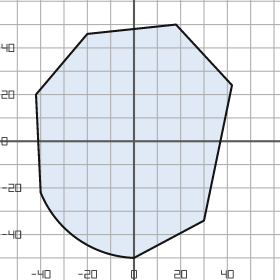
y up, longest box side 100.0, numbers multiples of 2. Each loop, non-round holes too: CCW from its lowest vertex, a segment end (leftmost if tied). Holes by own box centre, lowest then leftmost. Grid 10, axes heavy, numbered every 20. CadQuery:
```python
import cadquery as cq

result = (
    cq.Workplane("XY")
    .moveTo(0.0, -50.0)
    .lineTo(30.0, -34.0)
    .lineTo(42.0, 24.0)
    .lineTo(18.0, 50.0)
    .lineTo(-20.0, 46.0)
    .lineTo(-42.0, 20.0)
    .lineTo(-40.0, -22.0)
    .threePointArc((-24.0, -42.0), (0.0, -50.0))
    .close()
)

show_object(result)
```